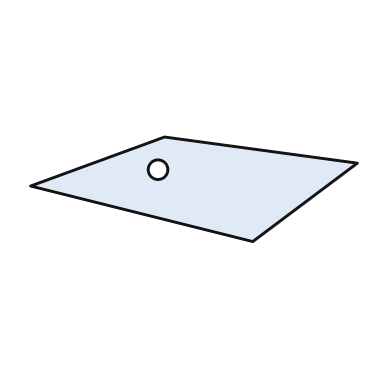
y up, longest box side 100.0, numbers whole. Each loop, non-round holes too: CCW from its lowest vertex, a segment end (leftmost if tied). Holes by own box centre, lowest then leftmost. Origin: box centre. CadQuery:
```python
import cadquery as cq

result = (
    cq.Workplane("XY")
    .moveTo(18.0, -16.0)
    .lineTo(50.0, 8.0)
    .lineTo(-9.0, 16.0)
    .lineTo(-50.0, 1.0)
    .close()
    .moveTo(-11.0, 6.0)
    .circle(3.0)
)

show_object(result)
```